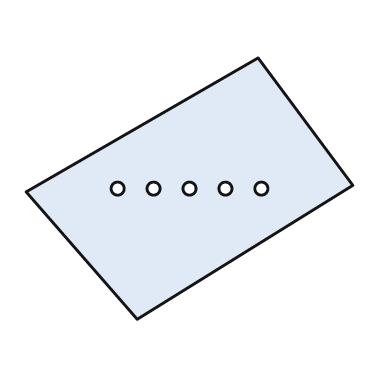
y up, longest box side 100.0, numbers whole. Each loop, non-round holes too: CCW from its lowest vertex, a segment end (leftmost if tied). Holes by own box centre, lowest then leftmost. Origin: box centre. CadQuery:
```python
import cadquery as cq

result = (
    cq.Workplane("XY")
    .moveTo(-16.0, -40.0)
    .lineTo(50.0, 1.0)
    .lineTo(21.0, 40.0)
    .lineTo(-50.0, -1.0)
    .close()
    .moveTo(-22.0, 0.0)
    .circle(2.0)
    .moveTo(-11.0, 0.0)
    .circle(2.0)
    .moveTo(0.0, 0.0)
    .circle(2.0)
    .moveTo(11.0, 0.0)
    .circle(2.0)
    .moveTo(22.0, 0.0)
    .circle(2.0)
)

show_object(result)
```